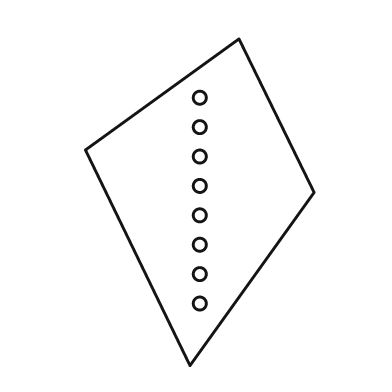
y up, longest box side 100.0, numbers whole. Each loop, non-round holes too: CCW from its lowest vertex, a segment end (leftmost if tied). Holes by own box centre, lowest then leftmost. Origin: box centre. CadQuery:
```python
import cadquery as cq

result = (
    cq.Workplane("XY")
    .moveTo(-3.0, -50.0)
    .lineTo(35.0, 3.0)
    .lineTo(12.0, 50.0)
    .lineTo(-35.0, 16.0)
    .close()
    .moveTo(0.0, -31.0)
    .circle(2.0)
    .moveTo(0.0, -22.0)
    .circle(2.0)
    .moveTo(0.0, -13.0)
    .circle(2.0)
    .moveTo(0.0, -4.0)
    .circle(2.0)
    .moveTo(0.0, 5.0)
    .circle(2.0)
    .moveTo(0.0, 14.0)
    .circle(2.0)
    .moveTo(0.0, 23.0)
    .circle(2.0)
    .moveTo(0.0, 32.0)
    .circle(2.0)
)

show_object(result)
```